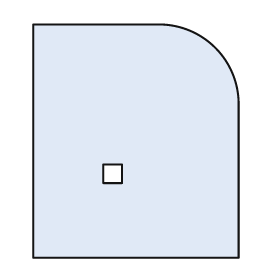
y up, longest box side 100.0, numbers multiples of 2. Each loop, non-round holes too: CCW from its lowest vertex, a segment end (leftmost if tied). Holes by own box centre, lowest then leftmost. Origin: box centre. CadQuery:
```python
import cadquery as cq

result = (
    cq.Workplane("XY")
    .moveTo(-44.0, -50.0)
    .lineTo(44.0, -50.0)
    .lineTo(44.0, 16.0)
    .threePointArc((34.0, 40.0), (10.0, 50.0))
    .lineTo(-44.0, 50.0)
    .close()
    .moveTo(-14.0, -18.0)
    .lineTo(-6.0, -18.0)
    .lineTo(-6.0, -10.0)
    .lineTo(-14.0, -10.0)
    .close()
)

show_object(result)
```